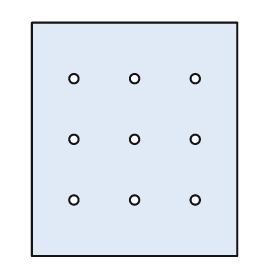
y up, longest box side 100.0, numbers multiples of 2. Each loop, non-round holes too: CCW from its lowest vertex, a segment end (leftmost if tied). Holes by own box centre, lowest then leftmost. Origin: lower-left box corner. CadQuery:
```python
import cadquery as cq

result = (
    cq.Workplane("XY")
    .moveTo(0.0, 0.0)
    .lineTo(88.0, 0.0)
    .lineTo(88.0, 100.0)
    .lineTo(0.0, 100.0)
    .close()
    .moveTo(18.0, 24.0)
    .circle(2.0)
    .moveTo(44.0, 24.0)
    .circle(2.0)
    .moveTo(70.0, 24.0)
    .circle(2.0)
    .moveTo(18.0, 50.0)
    .circle(2.0)
    .moveTo(44.0, 50.0)
    .circle(2.0)
    .moveTo(70.0, 50.0)
    .circle(2.0)
    .moveTo(18.0, 76.0)
    .circle(2.0)
    .moveTo(44.0, 76.0)
    .circle(2.0)
    .moveTo(70.0, 76.0)
    .circle(2.0)
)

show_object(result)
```